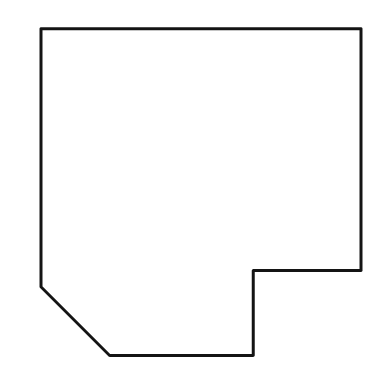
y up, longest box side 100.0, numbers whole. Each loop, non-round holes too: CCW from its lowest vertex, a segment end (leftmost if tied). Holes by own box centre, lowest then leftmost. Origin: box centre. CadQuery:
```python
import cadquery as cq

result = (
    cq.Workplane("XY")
    .moveTo(-28.0, -50.0)
    .lineTo(16.0, -50.0)
    .lineTo(16.0, -24.0)
    .lineTo(49.0, -24.0)
    .lineTo(49.0, 50.0)
    .lineTo(-49.0, 50.0)
    .lineTo(-49.0, -29.0)
    .close()
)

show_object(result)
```